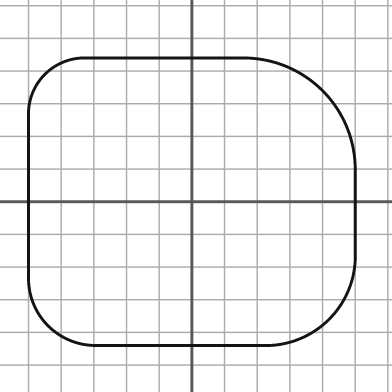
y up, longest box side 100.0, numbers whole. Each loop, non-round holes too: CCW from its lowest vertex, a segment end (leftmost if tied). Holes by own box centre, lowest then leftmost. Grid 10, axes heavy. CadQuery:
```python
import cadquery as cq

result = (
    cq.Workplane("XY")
    .moveTo(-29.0, -44.0)
    .lineTo(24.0, -44.0)
    .threePointArc((42.0, -36.0), (50.0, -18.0))
    .lineTo(50.0, 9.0)
    .threePointArc((40.0, 34.0), (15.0, 44.0))
    .lineTo(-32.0, 44.0)
    .threePointArc((-45.0, 39.0), (-50.0, 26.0))
    .lineTo(-50.0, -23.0)
    .threePointArc((-44.0, -38.0), (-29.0, -44.0))
    .close()
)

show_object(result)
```